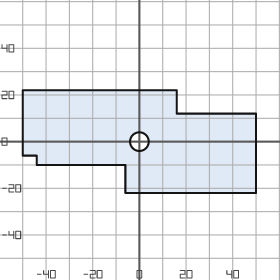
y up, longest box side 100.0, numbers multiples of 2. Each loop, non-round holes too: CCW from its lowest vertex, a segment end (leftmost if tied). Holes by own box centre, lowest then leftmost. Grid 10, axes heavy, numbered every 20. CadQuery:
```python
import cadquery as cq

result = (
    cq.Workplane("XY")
    .moveTo(-6.0, -22.0)
    .lineTo(50.0, -22.0)
    .lineTo(50.0, 12.0)
    .lineTo(16.0, 12.0)
    .lineTo(16.0, 22.0)
    .lineTo(-50.0, 22.0)
    .lineTo(-50.0, -6.0)
    .lineTo(-44.0, -6.0)
    .lineTo(-44.0, -10.0)
    .lineTo(-6.0, -10.0)
    .close()
    .moveTo(0.0, 0.0)
    .circle(4.0)
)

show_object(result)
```